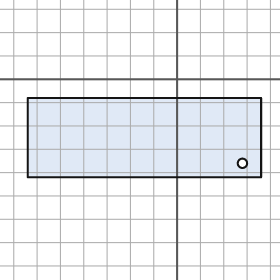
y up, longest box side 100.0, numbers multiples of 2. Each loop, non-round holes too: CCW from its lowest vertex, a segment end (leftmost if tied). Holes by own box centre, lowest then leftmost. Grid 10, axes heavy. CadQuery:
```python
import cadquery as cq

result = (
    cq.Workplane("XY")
    .moveTo(-64.0, -42.0)
    .lineTo(36.0, -42.0)
    .lineTo(36.0, -8.0)
    .lineTo(-64.0, -8.0)
    .close()
    .moveTo(28.0, -36.0)
    .circle(2.0)
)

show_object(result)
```